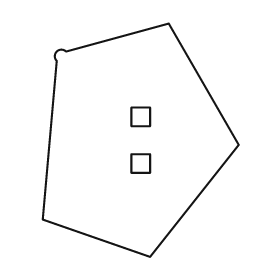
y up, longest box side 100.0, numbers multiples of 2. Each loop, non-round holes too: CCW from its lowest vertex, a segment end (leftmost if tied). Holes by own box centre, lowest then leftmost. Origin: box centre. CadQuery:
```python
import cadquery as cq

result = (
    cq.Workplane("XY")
    .moveTo(4.0, -50.0)
    .lineTo(42.0, -2.0)
    .lineTo(12.0, 50.0)
    .lineTo(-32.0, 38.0)
    .threePointArc((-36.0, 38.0), (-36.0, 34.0))
    .lineTo(-42.0, -34.0)
    .close()
    .moveTo(-4.0, -14.0)
    .lineTo(4.0, -14.0)
    .lineTo(4.0, -6.0)
    .lineTo(-4.0, -6.0)
    .close()
    .moveTo(-4.0, 6.0)
    .lineTo(4.0, 6.0)
    .lineTo(4.0, 14.0)
    .lineTo(-4.0, 14.0)
    .close()
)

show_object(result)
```